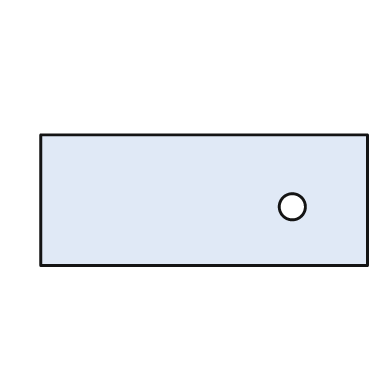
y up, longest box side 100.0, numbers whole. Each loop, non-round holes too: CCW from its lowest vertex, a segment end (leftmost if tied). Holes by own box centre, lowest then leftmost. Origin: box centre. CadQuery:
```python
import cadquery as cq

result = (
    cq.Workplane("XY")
    .moveTo(-50.0, -20.0)
    .lineTo(50.0, -20.0)
    .lineTo(50.0, 20.0)
    .lineTo(-50.0, 20.0)
    .close()
    .moveTo(27.0, -2.0)
    .circle(4.0)
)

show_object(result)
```